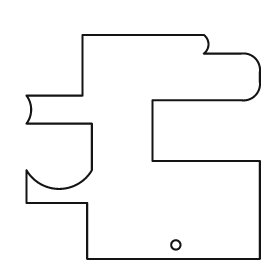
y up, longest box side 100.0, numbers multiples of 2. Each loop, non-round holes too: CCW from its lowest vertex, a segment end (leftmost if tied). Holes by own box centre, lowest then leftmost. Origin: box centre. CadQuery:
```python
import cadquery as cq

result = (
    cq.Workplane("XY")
    .moveTo(-24.0, -48.0)
    .lineTo(50.0, -48.0)
    .lineTo(50.0, -6.0)
    .lineTo(4.0, -6.0)
    .lineTo(4.0, 20.0)
    .lineTo(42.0, 20.0)
    .threePointArc((48.0, 22.0), (50.0, 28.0))
    .lineTo(50.0, 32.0)
    .threePointArc((48.0, 38.0), (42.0, 40.0))
    .lineTo(26.0, 40.0)
    .threePointArc((28.0, 44.0), (26.0, 48.0))
    .lineTo(-26.0, 48.0)
    .lineTo(-26.0, 22.0)
    .lineTo(-50.0, 22.0)
    .threePointArc((-48.0, 16.0), (-50.0, 10.0))
    .lineTo(-22.0, 10.0)
    .lineTo(-22.0, -10.0)
    .threePointArc((-36.0, -18.0), (-50.0, -10.0))
    .lineTo(-50.0, -24.0)
    .lineTo(-24.0, -24.0)
    .close()
    .moveTo(14.0, -42.0)
    .circle(2.0)
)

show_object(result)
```